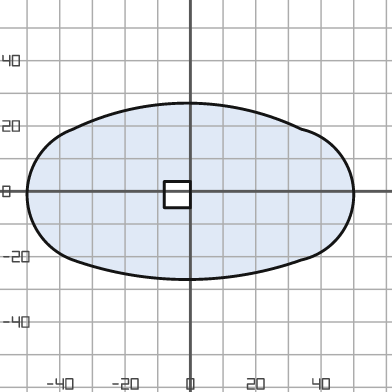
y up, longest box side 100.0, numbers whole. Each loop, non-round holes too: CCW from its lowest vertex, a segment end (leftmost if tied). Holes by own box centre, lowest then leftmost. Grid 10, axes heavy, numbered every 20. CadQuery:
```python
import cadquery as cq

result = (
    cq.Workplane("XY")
    .moveTo(-36.0, -21.0)
    .threePointArc((-1.0, -27.0), (34.0, -21.0))
    .threePointArc((50.0, -1.0), (34.0, 19.0))
    .threePointArc((-1.0, 27.0), (-36.0, 19.0))
    .threePointArc((-50.0, -1.0), (-36.0, -21.0))
    .close()
    .moveTo(-8.0, -5.0)
    .lineTo(0.0, -5.0)
    .lineTo(0.0, 3.0)
    .lineTo(-8.0, 3.0)
    .close()
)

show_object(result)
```